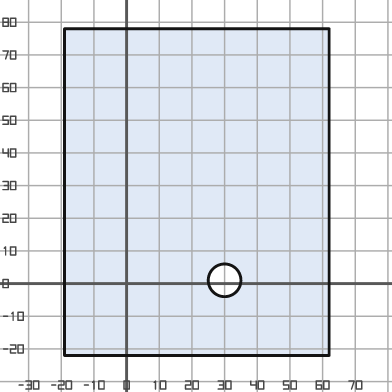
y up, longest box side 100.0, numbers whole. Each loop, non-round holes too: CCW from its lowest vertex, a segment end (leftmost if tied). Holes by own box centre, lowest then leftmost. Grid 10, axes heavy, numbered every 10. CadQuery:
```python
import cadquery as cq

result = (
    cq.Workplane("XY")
    .moveTo(-19.0, -22.0)
    .lineTo(62.0, -22.0)
    .lineTo(62.0, 78.0)
    .lineTo(-19.0, 78.0)
    .close()
    .moveTo(30.0, 1.0)
    .circle(5.0)
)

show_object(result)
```